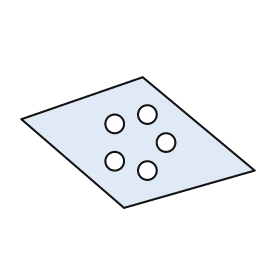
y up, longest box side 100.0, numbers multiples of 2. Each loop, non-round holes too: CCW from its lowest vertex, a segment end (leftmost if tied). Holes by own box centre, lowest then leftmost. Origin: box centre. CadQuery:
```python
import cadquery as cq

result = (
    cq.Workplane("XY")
    .moveTo(-6.0, -28.0)
    .lineTo(50.0, -12.0)
    .lineTo(2.0, 28.0)
    .lineTo(-50.0, 10.0)
    .close()
    .moveTo(4.0, -12.0)
    .circle(4.0)
    .moveTo(-10.0, -8.0)
    .circle(4.0)
    .moveTo(12.0, 0.0)
    .circle(4.0)
    .moveTo(-10.0, 8.0)
    .circle(4.0)
    .moveTo(4.0, 12.0)
    .circle(4.0)
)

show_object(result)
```